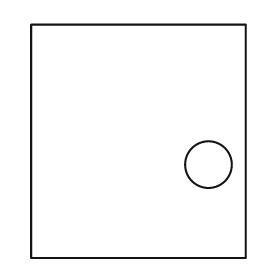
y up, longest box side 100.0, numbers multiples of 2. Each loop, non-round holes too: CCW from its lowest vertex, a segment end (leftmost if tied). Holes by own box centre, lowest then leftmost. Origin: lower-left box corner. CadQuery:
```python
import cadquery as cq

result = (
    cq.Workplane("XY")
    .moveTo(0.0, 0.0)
    .lineTo(92.0, 0.0)
    .lineTo(92.0, 100.0)
    .lineTo(0.0, 100.0)
    .close()
    .moveTo(76.0, 40.0)
    .circle(10.0)
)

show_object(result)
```